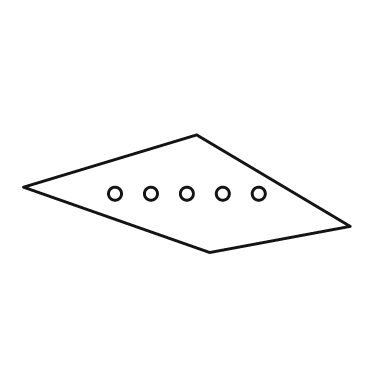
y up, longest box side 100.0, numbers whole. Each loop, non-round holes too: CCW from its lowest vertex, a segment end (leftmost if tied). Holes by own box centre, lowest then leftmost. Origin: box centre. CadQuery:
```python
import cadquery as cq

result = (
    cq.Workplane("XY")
    .moveTo(7.0, -18.0)
    .lineTo(50.0, -10.0)
    .lineTo(3.0, 18.0)
    .lineTo(-50.0, 2.0)
    .close()
    .moveTo(-22.0, 0.0)
    .circle(2.0)
    .moveTo(-11.0, 0.0)
    .circle(2.0)
    .moveTo(0.0, 0.0)
    .circle(2.0)
    .moveTo(11.0, 0.0)
    .circle(2.0)
    .moveTo(22.0, 0.0)
    .circle(2.0)
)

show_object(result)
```